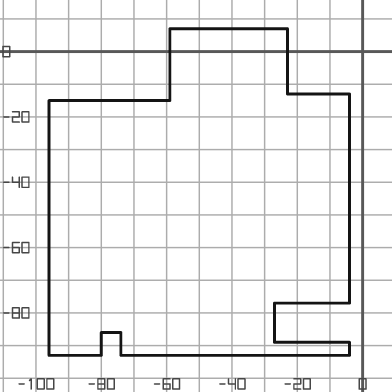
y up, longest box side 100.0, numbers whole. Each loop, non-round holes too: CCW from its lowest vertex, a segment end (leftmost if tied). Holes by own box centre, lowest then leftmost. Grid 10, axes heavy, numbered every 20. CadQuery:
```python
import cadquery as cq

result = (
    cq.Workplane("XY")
    .moveTo(-96.0, -93.0)
    .lineTo(-80.0, -93.0)
    .lineTo(-80.0, -86.0)
    .lineTo(-74.0, -86.0)
    .lineTo(-74.0, -93.0)
    .lineTo(-4.0, -93.0)
    .lineTo(-4.0, -89.0)
    .lineTo(-27.0, -89.0)
    .lineTo(-27.0, -77.0)
    .lineTo(-4.0, -77.0)
    .lineTo(-4.0, -13.0)
    .lineTo(-23.0, -13.0)
    .lineTo(-23.0, 7.0)
    .lineTo(-59.0, 7.0)
    .lineTo(-59.0, -15.0)
    .lineTo(-96.0, -15.0)
    .close()
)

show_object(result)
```